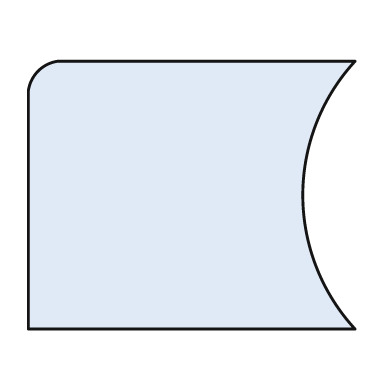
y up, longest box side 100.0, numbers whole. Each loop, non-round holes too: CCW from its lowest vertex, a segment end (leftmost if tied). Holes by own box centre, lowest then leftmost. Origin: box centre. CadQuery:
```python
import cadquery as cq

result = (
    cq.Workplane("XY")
    .moveTo(-50.0, -41.0)
    .lineTo(50.0, -41.0)
    .threePointArc((34.0, 0.0), (50.0, 41.0))
    .lineTo(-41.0, 41.0)
    .threePointArc((-47.0, 38.0), (-50.0, 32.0))
    .close()
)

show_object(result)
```